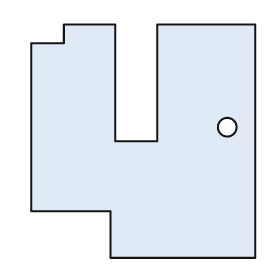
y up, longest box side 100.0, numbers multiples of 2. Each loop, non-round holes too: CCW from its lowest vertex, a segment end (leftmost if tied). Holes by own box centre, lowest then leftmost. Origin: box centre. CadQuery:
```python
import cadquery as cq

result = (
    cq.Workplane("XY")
    .moveTo(-14.0, -50.0)
    .lineTo(48.0, -50.0)
    .lineTo(48.0, 50.0)
    .lineTo(6.0, 50.0)
    .lineTo(6.0, 0.0)
    .lineTo(-12.0, 0.0)
    .lineTo(-12.0, 50.0)
    .lineTo(-34.0, 50.0)
    .lineTo(-34.0, 42.0)
    .lineTo(-48.0, 42.0)
    .lineTo(-48.0, -30.0)
    .lineTo(-14.0, -30.0)
    .close()
    .moveTo(36.0, 6.0)
    .circle(4.0)
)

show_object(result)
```